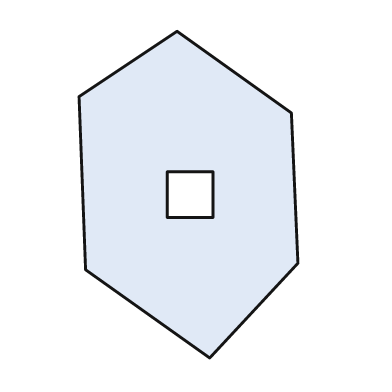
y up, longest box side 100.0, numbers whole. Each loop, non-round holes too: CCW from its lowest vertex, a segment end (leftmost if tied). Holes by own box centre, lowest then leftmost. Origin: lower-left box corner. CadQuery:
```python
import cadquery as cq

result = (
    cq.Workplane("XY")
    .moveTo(40.0, 0.0)
    .lineTo(67.0, 29.0)
    .lineTo(65.0, 75.0)
    .lineTo(30.0, 100.0)
    .lineTo(0.0, 80.0)
    .lineTo(2.0, 27.0)
    .close()
    .moveTo(27.0, 43.0)
    .lineTo(41.0, 43.0)
    .lineTo(41.0, 57.0)
    .lineTo(27.0, 57.0)
    .close()
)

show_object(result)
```